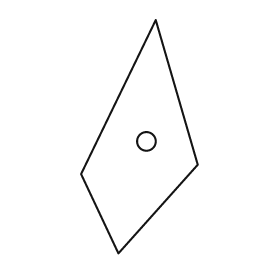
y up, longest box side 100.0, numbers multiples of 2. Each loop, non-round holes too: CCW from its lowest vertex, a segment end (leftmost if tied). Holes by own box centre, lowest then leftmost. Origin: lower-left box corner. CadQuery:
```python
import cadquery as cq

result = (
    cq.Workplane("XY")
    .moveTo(16.0, 0.0)
    .lineTo(50.0, 38.0)
    .lineTo(32.0, 100.0)
    .lineTo(0.0, 34.0)
    .close()
    .moveTo(28.0, 48.0)
    .circle(4.0)
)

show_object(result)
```